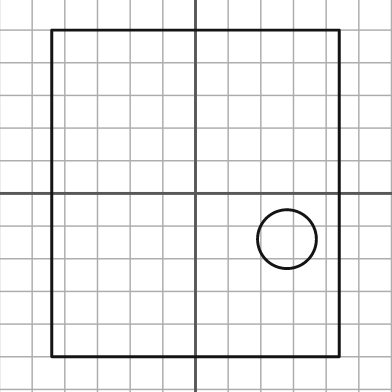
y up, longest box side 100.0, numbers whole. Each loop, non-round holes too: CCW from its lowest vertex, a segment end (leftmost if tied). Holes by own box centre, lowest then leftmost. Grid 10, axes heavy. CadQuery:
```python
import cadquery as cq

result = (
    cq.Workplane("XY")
    .moveTo(-44.0, -50.0)
    .lineTo(44.0, -50.0)
    .lineTo(44.0, 50.0)
    .lineTo(-44.0, 50.0)
    .close()
    .moveTo(28.0, -14.0)
    .circle(9.0)
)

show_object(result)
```